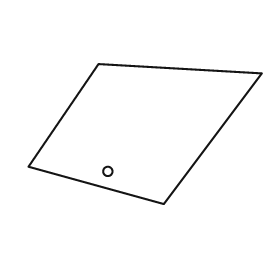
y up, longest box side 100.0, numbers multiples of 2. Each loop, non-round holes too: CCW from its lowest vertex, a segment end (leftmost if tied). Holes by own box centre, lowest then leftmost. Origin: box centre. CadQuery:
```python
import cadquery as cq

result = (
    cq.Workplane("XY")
    .moveTo(8.0, -30.0)
    .lineTo(50.0, 26.0)
    .lineTo(-20.0, 30.0)
    .lineTo(-50.0, -14.0)
    .close()
    .moveTo(-16.0, -16.0)
    .circle(2.0)
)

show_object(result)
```